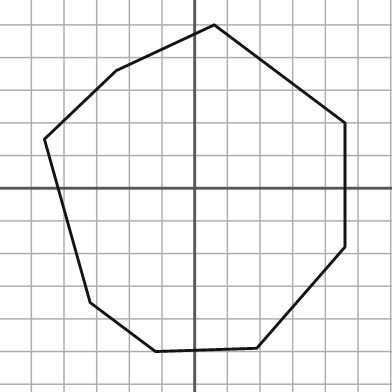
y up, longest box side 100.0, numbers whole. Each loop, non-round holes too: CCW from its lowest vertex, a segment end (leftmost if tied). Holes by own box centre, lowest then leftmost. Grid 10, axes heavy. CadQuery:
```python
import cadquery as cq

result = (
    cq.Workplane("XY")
    .moveTo(-12.0, -50.0)
    .lineTo(19.0, -49.0)
    .lineTo(46.0, -18.0)
    .lineTo(46.0, 20.0)
    .lineTo(6.0, 50.0)
    .lineTo(-24.0, 36.0)
    .lineTo(-46.0, 15.0)
    .lineTo(-32.0, -35.0)
    .close()
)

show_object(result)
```